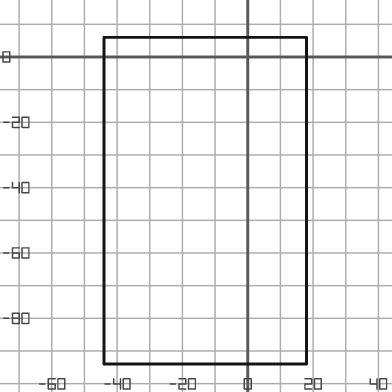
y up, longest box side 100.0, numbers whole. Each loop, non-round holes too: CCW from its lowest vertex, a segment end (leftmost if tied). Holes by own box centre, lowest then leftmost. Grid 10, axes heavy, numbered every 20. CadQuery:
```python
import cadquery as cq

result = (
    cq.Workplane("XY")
    .moveTo(-44.0, -94.0)
    .lineTo(18.0, -94.0)
    .lineTo(18.0, 6.0)
    .lineTo(-44.0, 6.0)
    .close()
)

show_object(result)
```